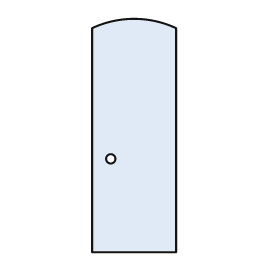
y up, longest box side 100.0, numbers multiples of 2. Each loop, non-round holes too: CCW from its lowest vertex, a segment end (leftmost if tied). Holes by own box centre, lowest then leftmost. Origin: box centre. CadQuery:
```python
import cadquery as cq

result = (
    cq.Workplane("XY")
    .moveTo(-18.0, -50.0)
    .lineTo(18.0, -50.0)
    .lineTo(18.0, 46.0)
    .threePointArc((0.0, 50.0), (-18.0, 46.0))
    .close()
    .moveTo(-10.0, -10.0)
    .circle(2.0)
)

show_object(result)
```